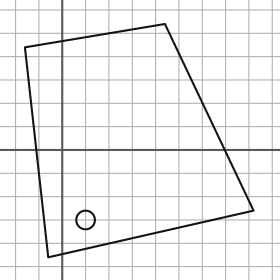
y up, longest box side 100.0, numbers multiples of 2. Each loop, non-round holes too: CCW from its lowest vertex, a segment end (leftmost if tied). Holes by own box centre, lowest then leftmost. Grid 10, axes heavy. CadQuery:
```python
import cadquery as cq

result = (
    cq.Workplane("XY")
    .moveTo(-6.0, -46.0)
    .lineTo(82.0, -26.0)
    .lineTo(44.0, 54.0)
    .lineTo(-16.0, 44.0)
    .close()
    .moveTo(10.0, -30.0)
    .circle(4.0)
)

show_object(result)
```